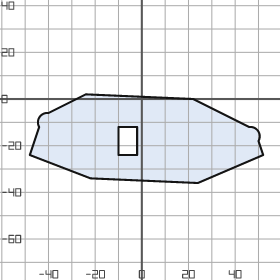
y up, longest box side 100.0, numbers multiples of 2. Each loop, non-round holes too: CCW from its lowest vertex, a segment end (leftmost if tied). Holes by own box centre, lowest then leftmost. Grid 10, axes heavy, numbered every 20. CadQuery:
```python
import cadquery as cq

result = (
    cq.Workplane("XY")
    .moveTo(24.0, -36.0)
    .lineTo(52.0, -24.0)
    .lineTo(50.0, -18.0)
    .threePointArc((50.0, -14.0), (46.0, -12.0))
    .lineTo(22.0, 0.0)
    .lineTo(-24.0, 2.0)
    .lineTo(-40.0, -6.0)
    .threePointArc((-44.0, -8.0), (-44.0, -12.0))
    .lineTo(-48.0, -24.0)
    .lineTo(-22.0, -34.0)
    .close()
    .moveTo(-10.0, -24.0)
    .lineTo(-2.0, -24.0)
    .lineTo(-2.0, -12.0)
    .lineTo(-10.0, -12.0)
    .close()
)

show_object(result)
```